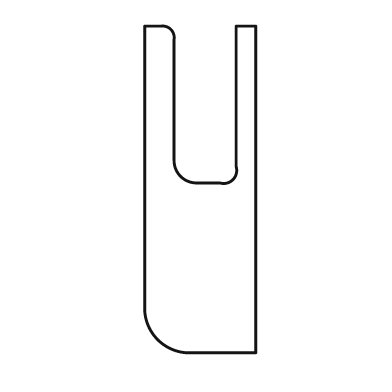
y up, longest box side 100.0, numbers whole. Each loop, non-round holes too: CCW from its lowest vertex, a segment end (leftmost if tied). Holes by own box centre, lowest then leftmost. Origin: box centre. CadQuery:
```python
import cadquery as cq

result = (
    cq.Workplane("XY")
    .moveTo(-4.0, -50.0)
    .lineTo(17.0, -50.0)
    .lineTo(17.0, 50.0)
    .lineTo(11.0, 50.0)
    .lineTo(11.0, 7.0)
    .threePointArc((10.0, 3.0), (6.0, 2.0))
    .lineTo(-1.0, 2.0)
    .threePointArc((-6.0, 4.0), (-8.0, 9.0))
    .lineTo(-8.0, 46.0)
    .threePointArc((-9.0, 49.0), (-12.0, 50.0))
    .lineTo(-17.0, 50.0)
    .lineTo(-17.0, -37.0)
    .threePointArc((-13.0, -46.0), (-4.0, -50.0))
    .close()
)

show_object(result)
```